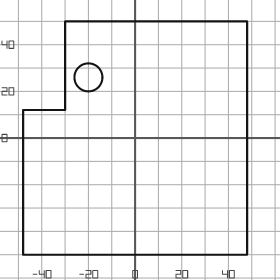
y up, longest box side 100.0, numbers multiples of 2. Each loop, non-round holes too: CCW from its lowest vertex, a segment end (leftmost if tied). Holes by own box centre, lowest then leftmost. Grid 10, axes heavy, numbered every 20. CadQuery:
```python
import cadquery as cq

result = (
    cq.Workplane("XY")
    .moveTo(-48.0, -50.0)
    .lineTo(48.0, -50.0)
    .lineTo(48.0, 50.0)
    .lineTo(-30.0, 50.0)
    .lineTo(-30.0, 12.0)
    .lineTo(-48.0, 12.0)
    .close()
    .moveTo(-20.0, 26.0)
    .circle(6.0)
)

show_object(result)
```